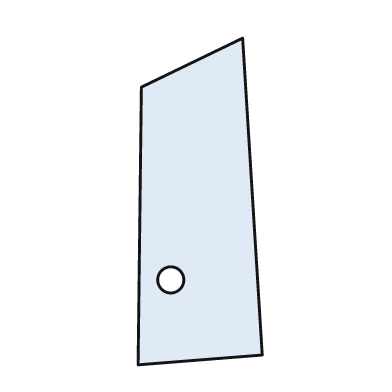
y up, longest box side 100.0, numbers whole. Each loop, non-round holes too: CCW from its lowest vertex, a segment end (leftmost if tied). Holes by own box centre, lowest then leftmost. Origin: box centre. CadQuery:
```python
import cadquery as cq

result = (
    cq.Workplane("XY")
    .moveTo(-19.0, -50.0)
    .lineTo(19.0, -47.0)
    .lineTo(13.0, 50.0)
    .lineTo(-18.0, 35.0)
    .close()
    .moveTo(-9.0, -24.0)
    .circle(4.0)
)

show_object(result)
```